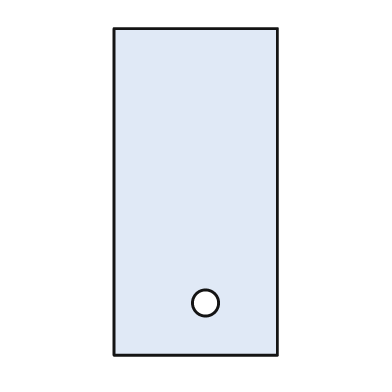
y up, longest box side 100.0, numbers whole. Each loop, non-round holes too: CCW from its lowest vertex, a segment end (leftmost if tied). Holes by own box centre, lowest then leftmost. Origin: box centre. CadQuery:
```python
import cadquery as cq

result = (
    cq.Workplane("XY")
    .moveTo(-25.0, -50.0)
    .lineTo(25.0, -50.0)
    .lineTo(25.0, 50.0)
    .lineTo(-25.0, 50.0)
    .close()
    .moveTo(3.0, -34.0)
    .circle(4.0)
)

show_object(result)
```